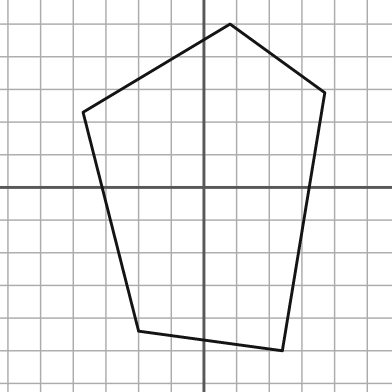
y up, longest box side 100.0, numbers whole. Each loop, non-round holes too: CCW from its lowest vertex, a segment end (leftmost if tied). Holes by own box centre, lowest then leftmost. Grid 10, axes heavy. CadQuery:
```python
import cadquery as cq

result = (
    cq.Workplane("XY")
    .moveTo(24.0, -50.0)
    .lineTo(37.0, 29.0)
    .lineTo(8.0, 50.0)
    .lineTo(-37.0, 23.0)
    .lineTo(-20.0, -44.0)
    .close()
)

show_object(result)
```